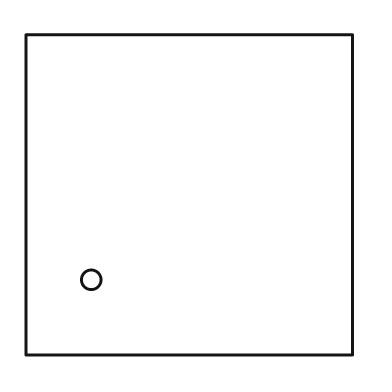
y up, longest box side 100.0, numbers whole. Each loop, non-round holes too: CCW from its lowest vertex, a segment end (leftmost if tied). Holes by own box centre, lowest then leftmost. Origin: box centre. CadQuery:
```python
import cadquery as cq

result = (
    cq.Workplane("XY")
    .moveTo(-50.0, -49.0)
    .lineTo(50.0, -49.0)
    .lineTo(50.0, 49.0)
    .lineTo(-50.0, 49.0)
    .close()
    .moveTo(-30.0, -26.0)
    .circle(3.0)
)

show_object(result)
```